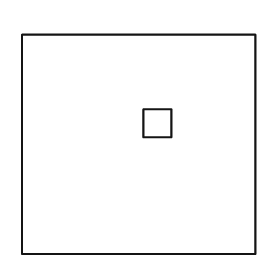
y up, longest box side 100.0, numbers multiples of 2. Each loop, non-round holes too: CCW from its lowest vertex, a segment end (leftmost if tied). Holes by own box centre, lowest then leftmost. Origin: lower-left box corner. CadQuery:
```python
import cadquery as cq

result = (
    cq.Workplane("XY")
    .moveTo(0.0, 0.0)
    .lineTo(100.0, 0.0)
    .lineTo(100.0, 94.0)
    .lineTo(0.0, 94.0)
    .close()
    .moveTo(52.0, 50.0)
    .lineTo(64.0, 50.0)
    .lineTo(64.0, 62.0)
    .lineTo(52.0, 62.0)
    .close()
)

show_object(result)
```